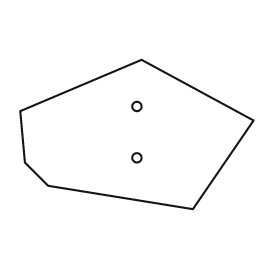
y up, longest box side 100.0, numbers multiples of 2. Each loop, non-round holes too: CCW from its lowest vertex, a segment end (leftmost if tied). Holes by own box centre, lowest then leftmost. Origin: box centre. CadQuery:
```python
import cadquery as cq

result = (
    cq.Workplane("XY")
    .moveTo(24.0, -32.0)
    .lineTo(50.0, 6.0)
    .lineTo(2.0, 32.0)
    .lineTo(-50.0, 10.0)
    .lineTo(-48.0, -12.0)
    .lineTo(-38.0, -22.0)
    .close()
    .moveTo(0.0, -10.0)
    .circle(2.0)
    .moveTo(0.0, 12.0)
    .circle(2.0)
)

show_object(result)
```